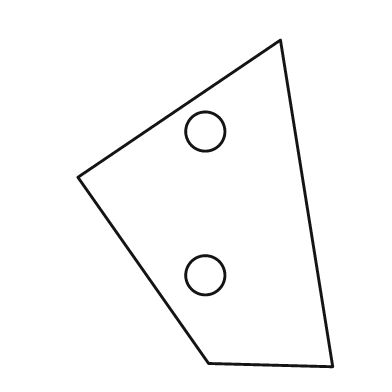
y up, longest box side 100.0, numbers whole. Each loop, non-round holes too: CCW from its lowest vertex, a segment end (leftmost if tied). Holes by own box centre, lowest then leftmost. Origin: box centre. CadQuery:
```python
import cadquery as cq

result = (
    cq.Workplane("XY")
    .moveTo(39.0, -50.0)
    .lineTo(23.0, 50.0)
    .lineTo(-39.0, 8.0)
    .lineTo(1.0, -49.0)
    .close()
    .moveTo(0.0, -22.0)
    .circle(6.0)
    .moveTo(0.0, 22.0)
    .circle(6.0)
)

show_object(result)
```